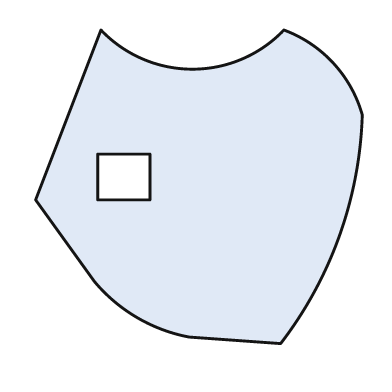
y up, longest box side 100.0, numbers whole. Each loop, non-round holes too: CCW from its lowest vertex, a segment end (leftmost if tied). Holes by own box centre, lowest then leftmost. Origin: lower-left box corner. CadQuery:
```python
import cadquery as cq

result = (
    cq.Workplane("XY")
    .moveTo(75.0, 0.0)
    .threePointArc((93.0, 33.0), (100.0, 70.0))
    .threePointArc((91.0, 86.0), (76.0, 96.0))
    .threePointArc((48.0, 84.0), (20.0, 96.0))
    .lineTo(0.0, 44.0)
    .lineTo(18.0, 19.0)
    .threePointArc((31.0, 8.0), (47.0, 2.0))
    .close()
    .moveTo(19.0, 44.0)
    .lineTo(35.0, 44.0)
    .lineTo(35.0, 58.0)
    .lineTo(19.0, 58.0)
    .close()
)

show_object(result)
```